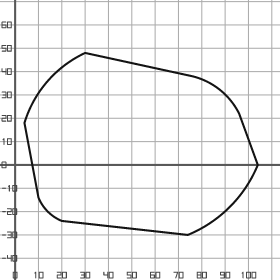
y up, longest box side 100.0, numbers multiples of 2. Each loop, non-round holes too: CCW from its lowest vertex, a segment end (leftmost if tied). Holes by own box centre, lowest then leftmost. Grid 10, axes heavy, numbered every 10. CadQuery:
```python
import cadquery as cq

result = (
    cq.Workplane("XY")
    .moveTo(74.0, -30.0)
    .threePointArc((92.0, -18.0), (104.0, 0.0))
    .lineTo(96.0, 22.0)
    .threePointArc((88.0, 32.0), (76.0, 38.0))
    .lineTo(30.0, 48.0)
    .threePointArc((14.0, 36.0), (4.0, 18.0))
    .lineTo(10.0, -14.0)
    .threePointArc((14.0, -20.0), (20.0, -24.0))
    .close()
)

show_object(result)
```